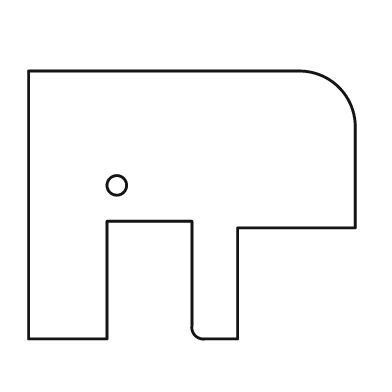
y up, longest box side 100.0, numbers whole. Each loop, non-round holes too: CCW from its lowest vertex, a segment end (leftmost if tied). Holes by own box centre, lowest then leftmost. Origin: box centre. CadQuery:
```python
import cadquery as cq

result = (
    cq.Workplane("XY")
    .moveTo(-50.0, -41.0)
    .lineTo(-26.0, -41.0)
    .lineTo(-26.0, -5.0)
    .lineTo(0.0, -5.0)
    .lineTo(0.0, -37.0)
    .threePointArc((1.0, -40.0), (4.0, -41.0))
    .lineTo(14.0, -41.0)
    .lineTo(14.0, -7.0)
    .lineTo(50.0, -7.0)
    .lineTo(50.0, 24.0)
    .threePointArc((45.0, 36.0), (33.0, 41.0))
    .lineTo(-50.0, 41.0)
    .close()
    .moveTo(-23.0, 6.0)
    .circle(3.0)
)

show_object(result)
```